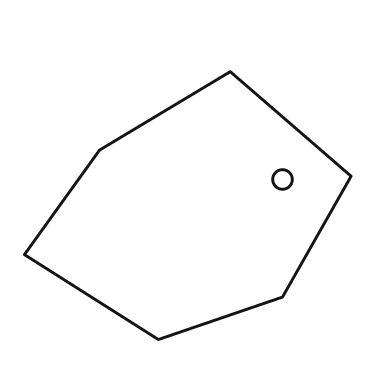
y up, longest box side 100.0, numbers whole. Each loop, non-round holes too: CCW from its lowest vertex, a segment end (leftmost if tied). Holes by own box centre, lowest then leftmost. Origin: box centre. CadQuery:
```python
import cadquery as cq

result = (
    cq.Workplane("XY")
    .moveTo(-9.0, -41.0)
    .lineTo(29.0, -28.0)
    .lineTo(50.0, 9.0)
    .lineTo(13.0, 41.0)
    .lineTo(-27.0, 17.0)
    .lineTo(-50.0, -15.0)
    .close()
    .moveTo(29.0, 8.0)
    .circle(3.0)
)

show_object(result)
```